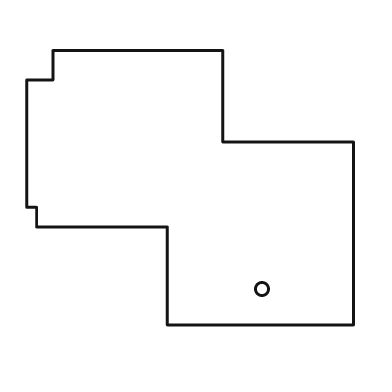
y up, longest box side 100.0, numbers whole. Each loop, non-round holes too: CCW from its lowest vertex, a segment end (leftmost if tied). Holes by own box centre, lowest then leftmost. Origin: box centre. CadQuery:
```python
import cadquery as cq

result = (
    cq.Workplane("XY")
    .moveTo(-7.0, -42.0)
    .lineTo(50.0, -42.0)
    .lineTo(50.0, 14.0)
    .lineTo(10.0, 14.0)
    .lineTo(10.0, 42.0)
    .lineTo(-42.0, 42.0)
    .lineTo(-42.0, 33.0)
    .lineTo(-50.0, 33.0)
    .lineTo(-50.0, -6.0)
    .lineTo(-47.0, -6.0)
    .lineTo(-47.0, -12.0)
    .lineTo(-7.0, -12.0)
    .close()
    .moveTo(22.0, -31.0)
    .circle(2.0)
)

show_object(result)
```